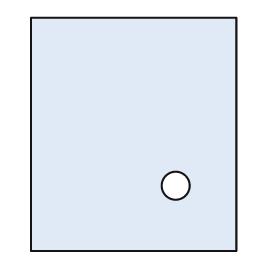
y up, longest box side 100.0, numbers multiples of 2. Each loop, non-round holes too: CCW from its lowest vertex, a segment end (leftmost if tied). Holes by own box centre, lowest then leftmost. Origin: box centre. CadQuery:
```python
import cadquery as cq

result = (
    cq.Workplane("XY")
    .moveTo(-44.0, -50.0)
    .lineTo(44.0, -50.0)
    .lineTo(44.0, 50.0)
    .lineTo(-44.0, 50.0)
    .close()
    .moveTo(18.0, -22.0)
    .circle(6.0)
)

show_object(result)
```